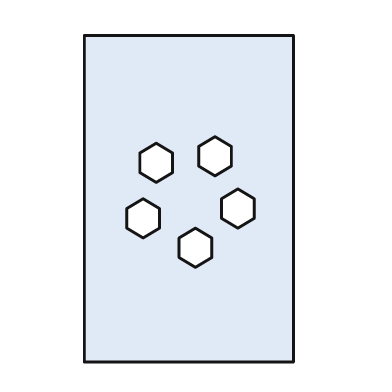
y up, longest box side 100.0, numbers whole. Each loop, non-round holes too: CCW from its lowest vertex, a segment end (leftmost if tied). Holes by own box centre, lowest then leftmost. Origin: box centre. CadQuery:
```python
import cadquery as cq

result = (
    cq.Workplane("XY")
    .moveTo(-32.0, -50.0)
    .lineTo(32.0, -50.0)
    .lineTo(32.0, 50.0)
    .lineTo(-32.0, 50.0)
    .close()
    .moveTo(2.0, -21.0)
    .lineTo(7.0, -18.0)
    .lineTo(7.0, -12.0)
    .lineTo(2.0, -9.0)
    .lineTo(-3.0, -12.0)
    .lineTo(-3.0, -18.0)
    .close()
    .moveTo(-14.0, -12.0)
    .lineTo(-9.0, -9.0)
    .lineTo(-9.0, -3.0)
    .lineTo(-14.0, 0.0)
    .lineTo(-19.0, -3.0)
    .lineTo(-19.0, -9.0)
    .close()
    .moveTo(15.0, -9.0)
    .lineTo(20.0, -6.0)
    .lineTo(20.0, 0.0)
    .lineTo(15.0, 3.0)
    .lineTo(10.0, 0.0)
    .lineTo(10.0, -6.0)
    .close()
    .moveTo(-10.0, 5.0)
    .lineTo(-5.0, 8.0)
    .lineTo(-5.0, 14.0)
    .lineTo(-10.0, 17.0)
    .lineTo(-15.0, 14.0)
    .lineTo(-15.0, 8.0)
    .close()
    .moveTo(8.0, 7.0)
    .lineTo(13.0, 10.0)
    .lineTo(13.0, 16.0)
    .lineTo(8.0, 19.0)
    .lineTo(3.0, 16.0)
    .lineTo(3.0, 10.0)
    .close()
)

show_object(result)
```